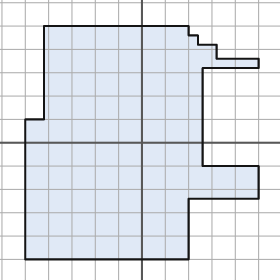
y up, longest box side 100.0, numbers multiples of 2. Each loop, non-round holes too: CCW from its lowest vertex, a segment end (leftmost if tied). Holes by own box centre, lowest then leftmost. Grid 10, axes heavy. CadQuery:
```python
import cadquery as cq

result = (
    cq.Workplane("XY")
    .moveTo(-50.0, -50.0)
    .lineTo(20.0, -50.0)
    .lineTo(20.0, -24.0)
    .lineTo(50.0, -24.0)
    .lineTo(50.0, -10.0)
    .lineTo(26.0, -10.0)
    .lineTo(26.0, 32.0)
    .lineTo(50.0, 32.0)
    .lineTo(50.0, 36.0)
    .lineTo(32.0, 36.0)
    .lineTo(32.0, 42.0)
    .lineTo(24.0, 42.0)
    .lineTo(24.0, 46.0)
    .lineTo(20.0, 46.0)
    .lineTo(20.0, 50.0)
    .lineTo(-42.0, 50.0)
    .lineTo(-42.0, 10.0)
    .lineTo(-50.0, 10.0)
    .close()
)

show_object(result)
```